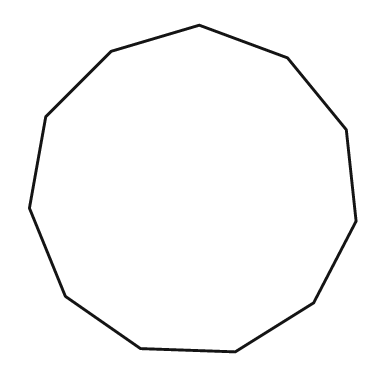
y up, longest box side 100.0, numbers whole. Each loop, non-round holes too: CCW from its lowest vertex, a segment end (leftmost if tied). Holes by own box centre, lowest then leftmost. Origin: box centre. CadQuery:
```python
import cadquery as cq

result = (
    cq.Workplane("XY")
    .moveTo(13.0, -50.0)
    .lineTo(37.0, -35.0)
    .lineTo(50.0, -10.0)
    .lineTo(47.0, 18.0)
    .lineTo(29.0, 40.0)
    .lineTo(2.0, 50.0)
    .lineTo(-25.0, 42.0)
    .lineTo(-45.0, 22.0)
    .lineTo(-50.0, -6.0)
    .lineTo(-39.0, -33.0)
    .lineTo(-16.0, -49.0)
    .close()
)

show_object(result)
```